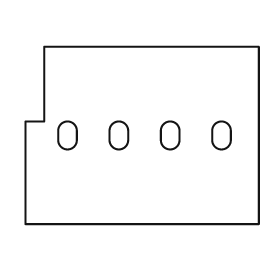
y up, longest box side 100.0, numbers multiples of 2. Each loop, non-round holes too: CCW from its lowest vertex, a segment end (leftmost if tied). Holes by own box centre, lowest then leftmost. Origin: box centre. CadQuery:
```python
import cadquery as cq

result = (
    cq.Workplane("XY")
    .moveTo(-50.0, -38.0)
    .lineTo(50.0, -38.0)
    .lineTo(50.0, 38.0)
    .lineTo(-42.0, 38.0)
    .lineTo(-42.0, 6.0)
    .lineTo(-50.0, 6.0)
    .close()
    .moveTo(-36.0, -2.0)
    .threePointArc((-32.0, -6.0), (-28.0, -2.0))
    .lineTo(-28.0, 2.0)
    .threePointArc((-32.0, 6.0), (-36.0, 2.0))
    .close()
    .moveTo(-14.0, -2.0)
    .threePointArc((-10.0, -6.0), (-6.0, -2.0))
    .lineTo(-6.0, 2.0)
    .threePointArc((-10.0, 6.0), (-14.0, 2.0))
    .close()
    .moveTo(8.0, -2.0)
    .threePointArc((12.0, -6.0), (16.0, -2.0))
    .lineTo(16.0, 2.0)
    .threePointArc((12.0, 6.0), (8.0, 2.0))
    .close()
    .moveTo(30.0, -2.0)
    .threePointArc((34.0, -6.0), (38.0, -2.0))
    .lineTo(38.0, 2.0)
    .threePointArc((34.0, 6.0), (30.0, 2.0))
    .close()
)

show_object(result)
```